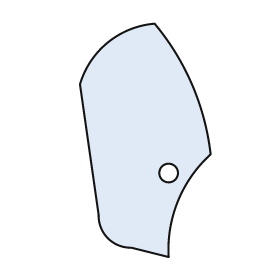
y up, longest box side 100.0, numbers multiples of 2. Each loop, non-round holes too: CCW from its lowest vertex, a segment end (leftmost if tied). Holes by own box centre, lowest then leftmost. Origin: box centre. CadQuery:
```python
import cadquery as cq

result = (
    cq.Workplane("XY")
    .moveTo(10.0, -50.0)
    .threePointArc((14.0, -26.0), (28.0, -6.0))
    .threePointArc((20.0, 24.0), (4.0, 50.0))
    .threePointArc((-16.0, 42.0), (-28.0, 24.0))
    .lineTo(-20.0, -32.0)
    .threePointArc((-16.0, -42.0), (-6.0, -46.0))
    .close()
    .moveTo(10.0, -14.0)
    .circle(4.0)
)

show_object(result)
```